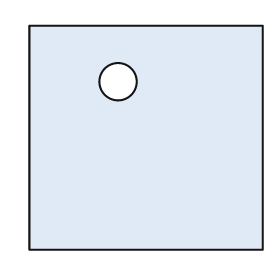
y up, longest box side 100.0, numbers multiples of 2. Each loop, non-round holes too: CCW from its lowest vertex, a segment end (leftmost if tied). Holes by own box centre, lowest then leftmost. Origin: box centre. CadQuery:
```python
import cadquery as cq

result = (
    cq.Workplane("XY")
    .moveTo(-50.0, -48.0)
    .lineTo(50.0, -48.0)
    .lineTo(50.0, 48.0)
    .lineTo(-50.0, 48.0)
    .close()
    .moveTo(-12.0, 24.0)
    .circle(8.0)
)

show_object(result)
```